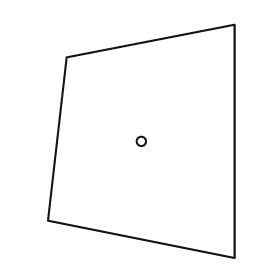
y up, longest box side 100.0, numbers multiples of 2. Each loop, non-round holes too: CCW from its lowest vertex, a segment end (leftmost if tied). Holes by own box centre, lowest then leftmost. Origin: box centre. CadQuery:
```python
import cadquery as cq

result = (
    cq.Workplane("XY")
    .moveTo(40.0, -50.0)
    .lineTo(40.0, 50.0)
    .lineTo(-32.0, 36.0)
    .lineTo(-40.0, -34.0)
    .close()
    .moveTo(0.0, 0.0)
    .circle(2.0)
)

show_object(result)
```